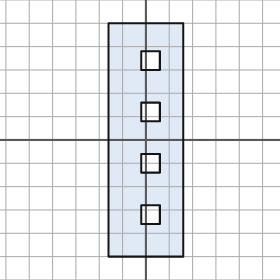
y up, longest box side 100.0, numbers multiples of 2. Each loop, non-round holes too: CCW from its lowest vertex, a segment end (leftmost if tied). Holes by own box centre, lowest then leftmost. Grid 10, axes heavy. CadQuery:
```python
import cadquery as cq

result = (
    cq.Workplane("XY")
    .moveTo(-16.0, -50.0)
    .lineTo(16.0, -50.0)
    .lineTo(16.0, 50.0)
    .lineTo(-16.0, 50.0)
    .close()
    .moveTo(-2.0, -36.0)
    .lineTo(6.0, -36.0)
    .lineTo(6.0, -28.0)
    .lineTo(-2.0, -28.0)
    .close()
    .moveTo(-2.0, -14.0)
    .lineTo(6.0, -14.0)
    .lineTo(6.0, -6.0)
    .lineTo(-2.0, -6.0)
    .close()
    .moveTo(-2.0, 8.0)
    .lineTo(6.0, 8.0)
    .lineTo(6.0, 16.0)
    .lineTo(-2.0, 16.0)
    .close()
    .moveTo(-2.0, 30.0)
    .lineTo(6.0, 30.0)
    .lineTo(6.0, 38.0)
    .lineTo(-2.0, 38.0)
    .close()
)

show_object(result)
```